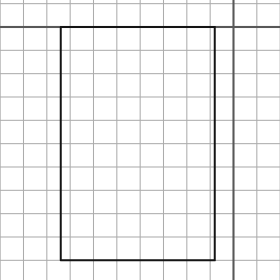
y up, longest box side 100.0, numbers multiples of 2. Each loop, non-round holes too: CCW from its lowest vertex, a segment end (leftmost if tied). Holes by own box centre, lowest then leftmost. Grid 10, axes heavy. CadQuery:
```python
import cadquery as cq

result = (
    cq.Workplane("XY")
    .moveTo(-74.0, -100.0)
    .lineTo(-8.0, -100.0)
    .lineTo(-8.0, 0.0)
    .lineTo(-74.0, 0.0)
    .close()
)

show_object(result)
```